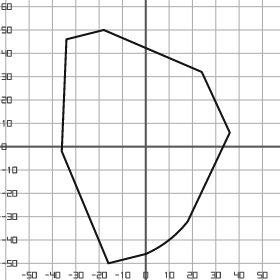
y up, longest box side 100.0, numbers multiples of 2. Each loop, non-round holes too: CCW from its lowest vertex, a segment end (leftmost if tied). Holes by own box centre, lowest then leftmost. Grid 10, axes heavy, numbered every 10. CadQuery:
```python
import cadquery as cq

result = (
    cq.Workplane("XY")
    .moveTo(-16.0, -50.0)
    .lineTo(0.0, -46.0)
    .threePointArc((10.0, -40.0), (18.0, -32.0))
    .lineTo(36.0, 6.0)
    .lineTo(24.0, 32.0)
    .lineTo(-18.0, 50.0)
    .lineTo(-34.0, 46.0)
    .lineTo(-36.0, -2.0)
    .close()
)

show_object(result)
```